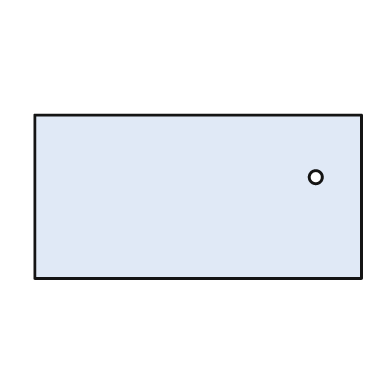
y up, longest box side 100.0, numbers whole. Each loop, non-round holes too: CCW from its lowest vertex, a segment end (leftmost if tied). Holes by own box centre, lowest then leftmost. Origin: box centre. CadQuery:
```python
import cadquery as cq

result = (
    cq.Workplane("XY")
    .moveTo(-50.0, -25.0)
    .lineTo(50.0, -25.0)
    .lineTo(50.0, 25.0)
    .lineTo(-50.0, 25.0)
    .close()
    .moveTo(36.0, 6.0)
    .circle(2.0)
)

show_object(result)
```